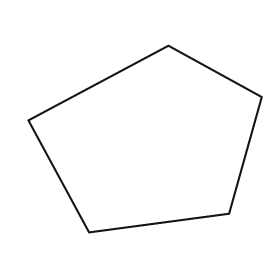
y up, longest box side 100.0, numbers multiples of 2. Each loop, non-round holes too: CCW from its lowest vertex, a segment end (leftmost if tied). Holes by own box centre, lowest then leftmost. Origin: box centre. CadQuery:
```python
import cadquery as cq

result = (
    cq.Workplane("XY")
    .moveTo(-24.0, -40.0)
    .lineTo(36.0, -32.0)
    .lineTo(50.0, 18.0)
    .lineTo(10.0, 40.0)
    .lineTo(-50.0, 8.0)
    .close()
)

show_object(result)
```